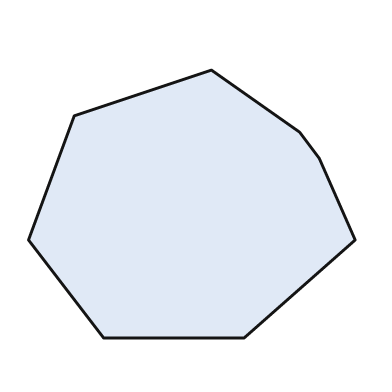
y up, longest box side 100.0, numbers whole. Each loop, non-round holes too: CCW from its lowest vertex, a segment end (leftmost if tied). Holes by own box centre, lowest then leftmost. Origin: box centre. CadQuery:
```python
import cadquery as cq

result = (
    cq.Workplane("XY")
    .moveTo(-27.0, -41.0)
    .lineTo(16.0, -41.0)
    .lineTo(50.0, -11.0)
    .lineTo(39.0, 14.0)
    .lineTo(33.0, 22.0)
    .lineTo(6.0, 41.0)
    .lineTo(-36.0, 27.0)
    .lineTo(-50.0, -11.0)
    .close()
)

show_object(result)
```